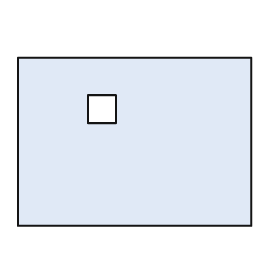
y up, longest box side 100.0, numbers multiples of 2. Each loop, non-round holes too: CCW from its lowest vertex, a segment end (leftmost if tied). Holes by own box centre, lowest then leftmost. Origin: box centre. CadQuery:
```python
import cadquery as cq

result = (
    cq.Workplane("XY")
    .moveTo(-50.0, -36.0)
    .lineTo(50.0, -36.0)
    .lineTo(50.0, 36.0)
    .lineTo(-50.0, 36.0)
    .close()
    .moveTo(-20.0, 8.0)
    .lineTo(-8.0, 8.0)
    .lineTo(-8.0, 20.0)
    .lineTo(-20.0, 20.0)
    .close()
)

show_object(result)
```